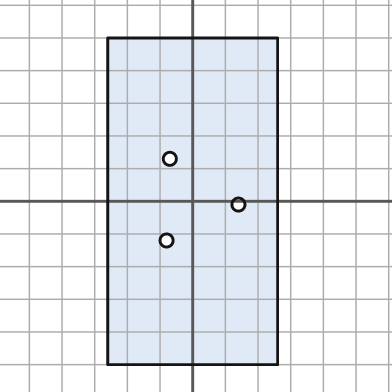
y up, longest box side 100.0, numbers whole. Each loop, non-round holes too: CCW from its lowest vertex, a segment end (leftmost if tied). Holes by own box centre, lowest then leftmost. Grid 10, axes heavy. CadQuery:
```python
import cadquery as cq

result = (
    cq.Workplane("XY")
    .moveTo(-26.0, -50.0)
    .lineTo(26.0, -50.0)
    .lineTo(26.0, 50.0)
    .lineTo(-26.0, 50.0)
    .close()
    .moveTo(-8.0, -12.0)
    .circle(2.0)
    .moveTo(14.0, -1.0)
    .circle(2.0)
    .moveTo(-7.0, 13.0)
    .circle(2.0)
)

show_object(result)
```